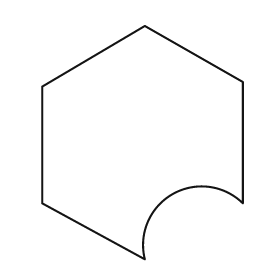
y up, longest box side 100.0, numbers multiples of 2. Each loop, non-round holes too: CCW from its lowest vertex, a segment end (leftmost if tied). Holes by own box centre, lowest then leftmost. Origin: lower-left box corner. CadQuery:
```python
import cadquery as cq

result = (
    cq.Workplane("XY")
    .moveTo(44.0, 0.0)
    .threePointArc((56.0, 28.0), (86.0, 24.0))
    .lineTo(86.0, 76.0)
    .lineTo(44.0, 100.0)
    .lineTo(0.0, 74.0)
    .lineTo(0.0, 24.0)
    .close()
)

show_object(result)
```